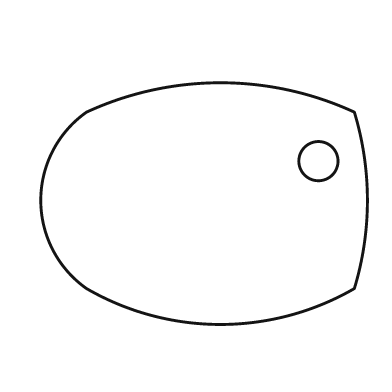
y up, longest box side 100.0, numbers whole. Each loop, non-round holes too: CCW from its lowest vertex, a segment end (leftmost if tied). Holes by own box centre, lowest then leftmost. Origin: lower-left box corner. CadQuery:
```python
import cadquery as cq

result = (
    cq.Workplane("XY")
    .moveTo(14.0, 11.0)
    .threePointArc((55.0, 0.0), (96.0, 11.0))
    .threePointArc((100.0, 38.0), (96.0, 65.0))
    .threePointArc((55.0, 74.0), (14.0, 65.0))
    .threePointArc((0.0, 38.0), (14.0, 11.0))
    .close()
    .moveTo(85.0, 50.0)
    .circle(6.0)
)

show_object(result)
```